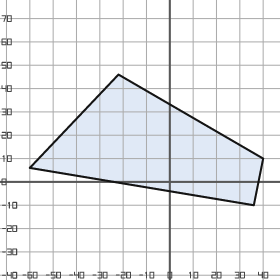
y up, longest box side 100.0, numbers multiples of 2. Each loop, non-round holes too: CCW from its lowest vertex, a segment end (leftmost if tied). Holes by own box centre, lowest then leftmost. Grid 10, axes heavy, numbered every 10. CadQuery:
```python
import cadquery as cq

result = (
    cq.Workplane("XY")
    .moveTo(36.0, -10.0)
    .lineTo(40.0, 10.0)
    .lineTo(-22.0, 46.0)
    .lineTo(-60.0, 6.0)
    .close()
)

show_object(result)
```